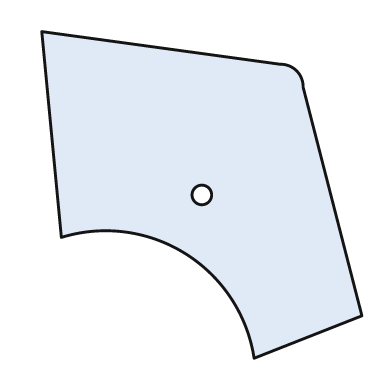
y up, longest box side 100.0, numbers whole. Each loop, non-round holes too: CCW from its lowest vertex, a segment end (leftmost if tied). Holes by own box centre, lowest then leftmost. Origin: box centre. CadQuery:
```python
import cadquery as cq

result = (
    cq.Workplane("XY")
    .moveTo(16.0, -50.0)
    .lineTo(49.0, -37.0)
    .lineTo(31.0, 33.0)
    .threePointArc((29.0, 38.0), (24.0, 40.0))
    .lineTo(-49.0, 50.0)
    .lineTo(-43.0, -13.0)
    .threePointArc((-5.0, -18.0), (16.0, -50.0))
    .close()
    .moveTo(0.0, 0.0)
    .circle(3.0)
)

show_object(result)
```